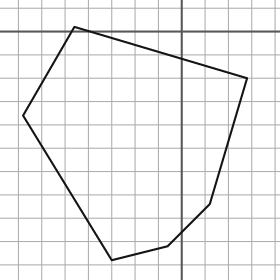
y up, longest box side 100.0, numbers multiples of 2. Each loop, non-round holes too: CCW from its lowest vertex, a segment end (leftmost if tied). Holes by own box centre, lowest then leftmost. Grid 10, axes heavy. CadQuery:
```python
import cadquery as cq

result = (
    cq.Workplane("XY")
    .moveTo(-30.0, -98.0)
    .lineTo(-6.0, -92.0)
    .lineTo(12.0, -74.0)
    .lineTo(28.0, -20.0)
    .lineTo(-46.0, 2.0)
    .lineTo(-68.0, -36.0)
    .close()
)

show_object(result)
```